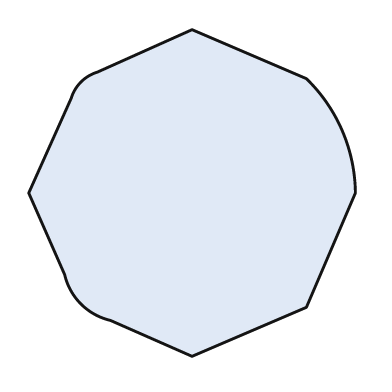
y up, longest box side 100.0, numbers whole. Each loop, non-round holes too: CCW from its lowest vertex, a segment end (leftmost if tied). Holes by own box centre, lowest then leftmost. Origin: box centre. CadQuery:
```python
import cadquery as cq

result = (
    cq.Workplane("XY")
    .moveTo(0.0, -50.0)
    .lineTo(35.0, -35.0)
    .lineTo(50.0, 0.0)
    .threePointArc((46.0, 19.0), (35.0, 35.0))
    .lineTo(0.0, 50.0)
    .lineTo(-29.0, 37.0)
    .threePointArc((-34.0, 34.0), (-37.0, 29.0))
    .lineTo(-50.0, 0.0)
    .lineTo(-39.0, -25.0)
    .threePointArc((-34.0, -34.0), (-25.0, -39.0))
    .close()
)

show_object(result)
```